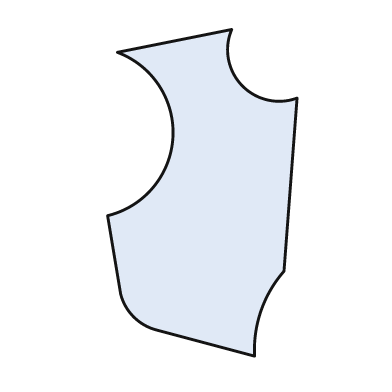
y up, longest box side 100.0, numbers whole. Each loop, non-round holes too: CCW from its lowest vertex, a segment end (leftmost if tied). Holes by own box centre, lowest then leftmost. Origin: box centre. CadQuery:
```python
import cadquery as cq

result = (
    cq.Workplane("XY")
    .moveTo(16.0, -50.0)
    .threePointArc((18.0, -36.0), (25.0, -24.0))
    .lineTo(29.0, 29.0)
    .threePointArc((12.0, 33.0), (9.0, 50.0))
    .lineTo(-26.0, 43.0)
    .threePointArc((-9.0, 17.0), (-29.0, -7.0))
    .lineTo(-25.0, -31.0)
    .threePointArc((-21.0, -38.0), (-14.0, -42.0))
    .close()
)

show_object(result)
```